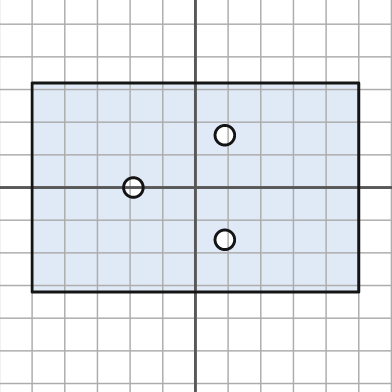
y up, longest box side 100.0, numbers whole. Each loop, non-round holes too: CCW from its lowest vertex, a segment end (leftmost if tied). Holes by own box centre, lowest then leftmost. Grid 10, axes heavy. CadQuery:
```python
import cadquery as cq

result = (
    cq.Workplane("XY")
    .moveTo(-50.0, -32.0)
    .lineTo(50.0, -32.0)
    .lineTo(50.0, 32.0)
    .lineTo(-50.0, 32.0)
    .close()
    .moveTo(9.0, -16.0)
    .circle(3.0)
    .moveTo(-19.0, 0.0)
    .circle(3.0)
    .moveTo(9.0, 16.0)
    .circle(3.0)
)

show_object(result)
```